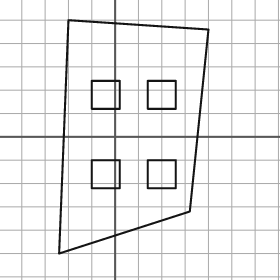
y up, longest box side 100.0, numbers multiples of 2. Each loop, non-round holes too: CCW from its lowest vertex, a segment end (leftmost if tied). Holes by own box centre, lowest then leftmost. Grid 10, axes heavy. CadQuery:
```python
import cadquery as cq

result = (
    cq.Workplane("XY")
    .moveTo(-24.0, -50.0)
    .lineTo(32.0, -32.0)
    .lineTo(40.0, 46.0)
    .lineTo(-20.0, 50.0)
    .close()
    .moveTo(-10.0, -22.0)
    .lineTo(2.0, -22.0)
    .lineTo(2.0, -10.0)
    .lineTo(-10.0, -10.0)
    .close()
    .moveTo(14.0, -22.0)
    .lineTo(26.0, -22.0)
    .lineTo(26.0, -10.0)
    .lineTo(14.0, -10.0)
    .close()
    .moveTo(-10.0, 12.0)
    .lineTo(2.0, 12.0)
    .lineTo(2.0, 24.0)
    .lineTo(-10.0, 24.0)
    .close()
    .moveTo(14.0, 12.0)
    .lineTo(26.0, 12.0)
    .lineTo(26.0, 24.0)
    .lineTo(14.0, 24.0)
    .close()
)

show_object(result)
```